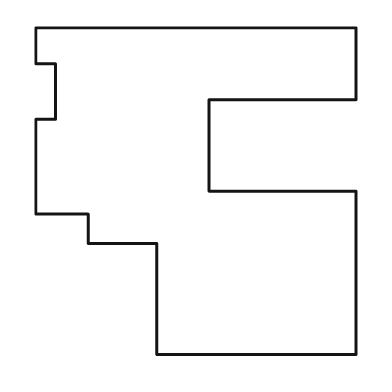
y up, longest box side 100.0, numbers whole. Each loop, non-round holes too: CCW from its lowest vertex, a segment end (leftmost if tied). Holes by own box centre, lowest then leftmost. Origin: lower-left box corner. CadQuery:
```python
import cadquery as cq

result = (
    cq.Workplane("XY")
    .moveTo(37.0, 0.0)
    .lineTo(98.0, 0.0)
    .lineTo(98.0, 50.0)
    .lineTo(53.0, 50.0)
    .lineTo(53.0, 78.0)
    .lineTo(98.0, 78.0)
    .lineTo(98.0, 100.0)
    .lineTo(0.0, 100.0)
    .lineTo(0.0, 89.0)
    .lineTo(6.0, 89.0)
    .lineTo(6.0, 72.0)
    .lineTo(0.0, 72.0)
    .lineTo(0.0, 43.0)
    .lineTo(16.0, 43.0)
    .lineTo(16.0, 34.0)
    .lineTo(37.0, 34.0)
    .close()
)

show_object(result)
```